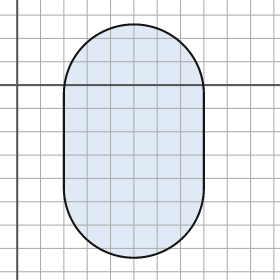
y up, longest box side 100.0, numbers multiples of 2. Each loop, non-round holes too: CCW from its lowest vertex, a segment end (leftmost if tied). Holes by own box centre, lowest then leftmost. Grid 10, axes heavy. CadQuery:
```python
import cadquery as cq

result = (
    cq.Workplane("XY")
    .moveTo(20.0, -44.0)
    .threePointArc((50.0, -74.0), (80.0, -44.0))
    .lineTo(80.0, -4.0)
    .threePointArc((50.0, 26.0), (20.0, -4.0))
    .close()
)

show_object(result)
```